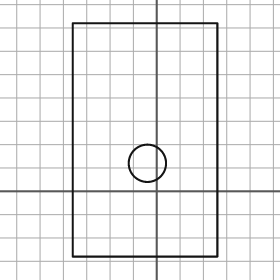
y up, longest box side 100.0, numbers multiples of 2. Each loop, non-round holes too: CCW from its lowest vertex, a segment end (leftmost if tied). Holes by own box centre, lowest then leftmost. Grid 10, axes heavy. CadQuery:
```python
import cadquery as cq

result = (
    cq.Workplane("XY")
    .moveTo(-36.0, -28.0)
    .lineTo(26.0, -28.0)
    .lineTo(26.0, 72.0)
    .lineTo(-36.0, 72.0)
    .close()
    .moveTo(-4.0, 12.0)
    .circle(8.0)
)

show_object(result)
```